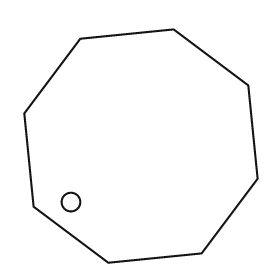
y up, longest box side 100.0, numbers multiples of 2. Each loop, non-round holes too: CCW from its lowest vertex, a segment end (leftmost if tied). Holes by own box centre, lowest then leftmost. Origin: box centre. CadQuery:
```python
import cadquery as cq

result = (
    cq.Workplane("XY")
    .moveTo(-14.0, -50.0)
    .lineTo(26.0, -46.0)
    .lineTo(50.0, -14.0)
    .lineTo(46.0, 26.0)
    .lineTo(14.0, 50.0)
    .lineTo(-26.0, 46.0)
    .lineTo(-50.0, 14.0)
    .lineTo(-46.0, -26.0)
    .close()
    .moveTo(-30.0, -24.0)
    .circle(4.0)
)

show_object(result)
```